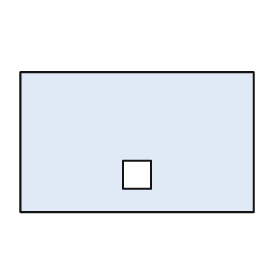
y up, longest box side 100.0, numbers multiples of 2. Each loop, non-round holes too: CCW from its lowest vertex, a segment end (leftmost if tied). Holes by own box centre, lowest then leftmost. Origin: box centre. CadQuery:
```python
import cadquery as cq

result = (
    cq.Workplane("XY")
    .moveTo(-50.0, -30.0)
    .lineTo(50.0, -30.0)
    .lineTo(50.0, 30.0)
    .lineTo(-50.0, 30.0)
    .close()
    .moveTo(-6.0, -20.0)
    .lineTo(6.0, -20.0)
    .lineTo(6.0, -8.0)
    .lineTo(-6.0, -8.0)
    .close()
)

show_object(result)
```